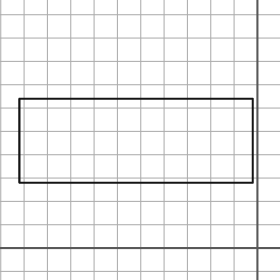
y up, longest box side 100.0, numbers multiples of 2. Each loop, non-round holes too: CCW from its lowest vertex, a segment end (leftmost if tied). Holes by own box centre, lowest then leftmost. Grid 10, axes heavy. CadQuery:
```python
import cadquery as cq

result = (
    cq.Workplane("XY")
    .moveTo(-102.0, 28.0)
    .lineTo(-2.0, 28.0)
    .lineTo(-2.0, 64.0)
    .lineTo(-102.0, 64.0)
    .close()
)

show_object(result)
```